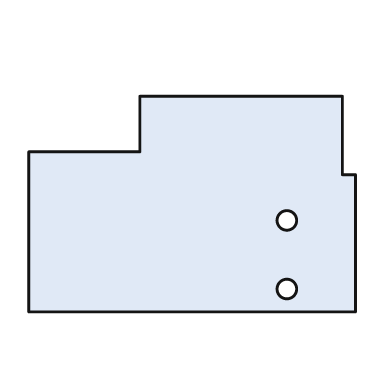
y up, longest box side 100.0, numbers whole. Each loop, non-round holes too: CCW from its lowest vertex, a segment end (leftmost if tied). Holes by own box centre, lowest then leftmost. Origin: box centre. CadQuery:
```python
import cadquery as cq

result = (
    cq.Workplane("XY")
    .moveTo(-50.0, -33.0)
    .lineTo(50.0, -33.0)
    .lineTo(50.0, 9.0)
    .lineTo(46.0, 9.0)
    .lineTo(46.0, 33.0)
    .lineTo(-16.0, 33.0)
    .lineTo(-16.0, 16.0)
    .lineTo(-50.0, 16.0)
    .close()
    .moveTo(29.0, -26.0)
    .circle(3.0)
    .moveTo(29.0, -5.0)
    .circle(3.0)
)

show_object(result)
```